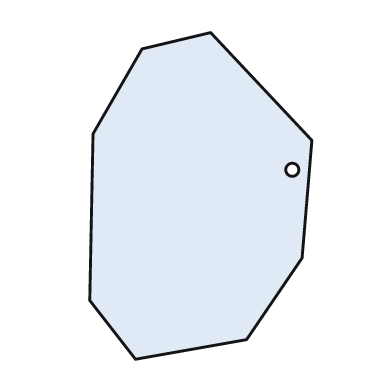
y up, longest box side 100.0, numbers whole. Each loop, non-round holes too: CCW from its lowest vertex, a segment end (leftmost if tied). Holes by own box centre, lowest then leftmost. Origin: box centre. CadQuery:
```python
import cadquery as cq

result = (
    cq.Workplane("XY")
    .moveTo(-20.0, -50.0)
    .lineTo(14.0, -44.0)
    .lineTo(31.0, -19.0)
    .lineTo(34.0, 17.0)
    .lineTo(3.0, 50.0)
    .lineTo(-18.0, 45.0)
    .lineTo(-33.0, 19.0)
    .lineTo(-34.0, -32.0)
    .close()
    .moveTo(28.0, 8.0)
    .circle(2.0)
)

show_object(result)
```